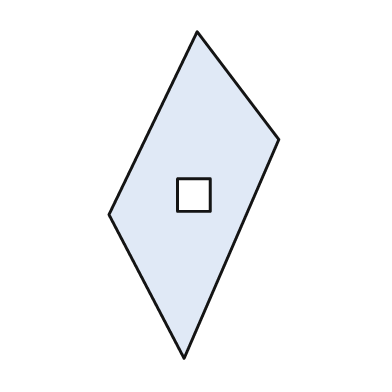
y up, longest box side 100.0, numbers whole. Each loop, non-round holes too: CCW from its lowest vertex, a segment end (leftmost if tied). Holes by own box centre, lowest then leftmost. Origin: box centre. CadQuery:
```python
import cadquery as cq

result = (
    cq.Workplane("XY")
    .moveTo(-3.0, -50.0)
    .lineTo(26.0, 17.0)
    .lineTo(1.0, 50.0)
    .lineTo(-26.0, -6.0)
    .close()
    .moveTo(-5.0, -5.0)
    .lineTo(5.0, -5.0)
    .lineTo(5.0, 5.0)
    .lineTo(-5.0, 5.0)
    .close()
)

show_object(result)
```